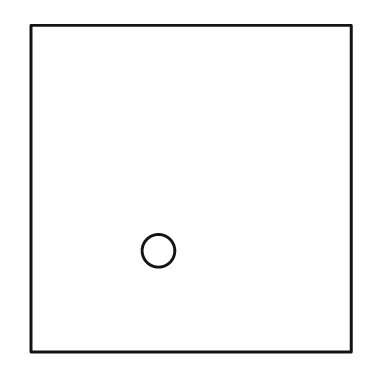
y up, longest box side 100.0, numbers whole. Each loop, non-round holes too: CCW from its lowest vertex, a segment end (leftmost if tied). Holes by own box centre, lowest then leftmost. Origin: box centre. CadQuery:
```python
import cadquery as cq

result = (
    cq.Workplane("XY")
    .moveTo(-49.0, -50.0)
    .lineTo(49.0, -50.0)
    .lineTo(49.0, 50.0)
    .lineTo(-49.0, 50.0)
    .close()
    .moveTo(-10.0, -19.0)
    .circle(5.0)
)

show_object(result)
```